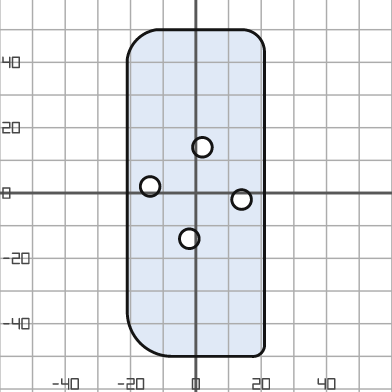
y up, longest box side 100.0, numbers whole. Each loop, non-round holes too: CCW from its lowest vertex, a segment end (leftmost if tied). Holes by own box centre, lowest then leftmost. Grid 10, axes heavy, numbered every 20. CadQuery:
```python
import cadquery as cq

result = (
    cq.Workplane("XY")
    .moveTo(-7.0, -50.0)
    .lineTo(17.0, -50.0)
    .threePointArc((20.0, -49.0), (21.0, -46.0))
    .lineTo(21.0, 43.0)
    .threePointArc((19.0, 48.0), (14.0, 50.0))
    .lineTo(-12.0, 50.0)
    .threePointArc((-18.0, 47.0), (-21.0, 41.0))
    .lineTo(-21.0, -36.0)
    .threePointArc((-17.0, -46.0), (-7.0, -50.0))
    .close()
    .moveTo(-2.0, -14.0)
    .circle(3.0)
    .moveTo(14.0, -2.0)
    .circle(3.0)
    .moveTo(-14.0, 2.0)
    .circle(3.0)
    .moveTo(2.0, 14.0)
    .circle(3.0)
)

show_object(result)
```